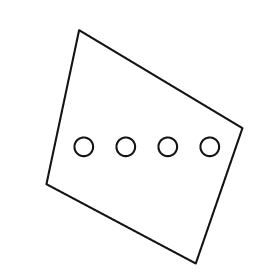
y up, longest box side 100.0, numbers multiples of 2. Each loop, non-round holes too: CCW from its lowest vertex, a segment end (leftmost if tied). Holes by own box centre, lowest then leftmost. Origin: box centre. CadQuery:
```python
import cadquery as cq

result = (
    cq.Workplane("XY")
    .moveTo(22.0, -50.0)
    .lineTo(42.0, 8.0)
    .lineTo(-28.0, 50.0)
    .lineTo(-42.0, -16.0)
    .close()
    .moveTo(-26.0, 0.0)
    .circle(4.0)
    .moveTo(-8.0, 0.0)
    .circle(4.0)
    .moveTo(10.0, 0.0)
    .circle(4.0)
    .moveTo(28.0, 0.0)
    .circle(4.0)
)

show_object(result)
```